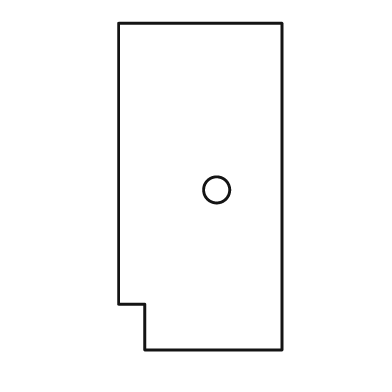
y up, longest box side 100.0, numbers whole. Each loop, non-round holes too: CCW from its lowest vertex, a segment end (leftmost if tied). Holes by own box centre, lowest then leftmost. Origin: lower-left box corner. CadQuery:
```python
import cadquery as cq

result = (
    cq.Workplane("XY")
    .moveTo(8.0, 0.0)
    .lineTo(50.0, 0.0)
    .lineTo(50.0, 100.0)
    .lineTo(0.0, 100.0)
    .lineTo(0.0, 14.0)
    .lineTo(8.0, 14.0)
    .close()
    .moveTo(30.0, 49.0)
    .circle(4.0)
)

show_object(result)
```